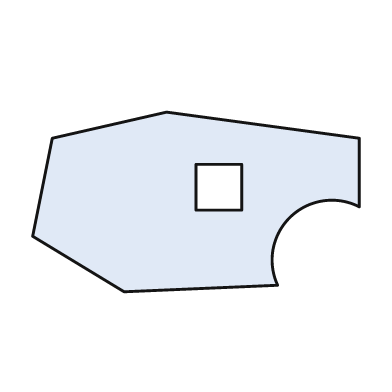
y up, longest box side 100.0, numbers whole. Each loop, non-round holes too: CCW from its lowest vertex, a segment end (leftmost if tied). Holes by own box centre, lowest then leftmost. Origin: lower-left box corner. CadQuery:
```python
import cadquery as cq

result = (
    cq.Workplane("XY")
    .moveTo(28.0, 0.0)
    .lineTo(75.0, 2.0)
    .threePointArc((79.0, 23.0), (100.0, 26.0))
    .lineTo(100.0, 47.0)
    .lineTo(41.0, 55.0)
    .lineTo(6.0, 47.0)
    .lineTo(0.0, 17.0)
    .close()
    .moveTo(50.0, 25.0)
    .lineTo(64.0, 25.0)
    .lineTo(64.0, 39.0)
    .lineTo(50.0, 39.0)
    .close()
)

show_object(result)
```